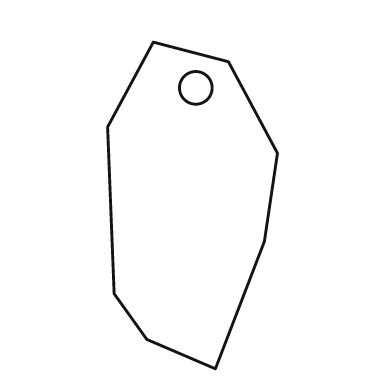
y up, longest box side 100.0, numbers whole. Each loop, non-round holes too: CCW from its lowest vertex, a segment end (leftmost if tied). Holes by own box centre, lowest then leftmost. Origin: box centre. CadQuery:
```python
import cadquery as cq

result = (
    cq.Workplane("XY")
    .moveTo(7.0, -50.0)
    .lineTo(22.0, -11.0)
    .lineTo(26.0, 16.0)
    .lineTo(11.0, 44.0)
    .lineTo(-12.0, 50.0)
    .lineTo(-26.0, 24.0)
    .lineTo(-24.0, -27.0)
    .lineTo(-14.0, -41.0)
    .close()
    .moveTo(1.0, 36.0)
    .circle(5.0)
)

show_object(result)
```